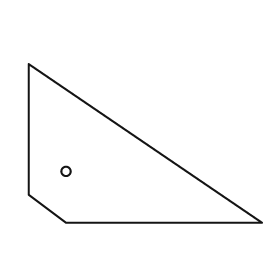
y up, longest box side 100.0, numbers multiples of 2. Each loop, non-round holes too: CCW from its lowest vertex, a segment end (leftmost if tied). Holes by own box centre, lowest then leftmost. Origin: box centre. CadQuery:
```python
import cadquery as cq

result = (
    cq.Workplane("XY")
    .moveTo(-34.0, -34.0)
    .lineTo(50.0, -34.0)
    .lineTo(-50.0, 34.0)
    .lineTo(-50.0, -22.0)
    .close()
    .moveTo(-34.0, -12.0)
    .circle(2.0)
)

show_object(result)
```